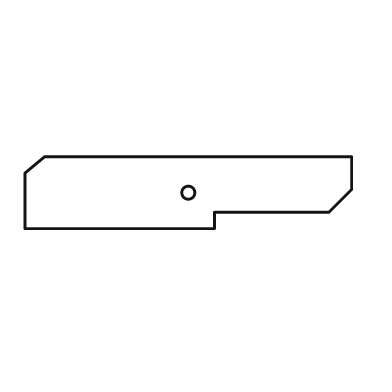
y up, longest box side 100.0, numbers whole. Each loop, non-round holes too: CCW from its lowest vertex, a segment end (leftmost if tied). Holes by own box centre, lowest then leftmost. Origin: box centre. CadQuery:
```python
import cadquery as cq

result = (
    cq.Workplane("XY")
    .moveTo(-50.0, -11.0)
    .lineTo(8.0, -11.0)
    .lineTo(8.0, -6.0)
    .lineTo(43.0, -6.0)
    .lineTo(50.0, 1.0)
    .lineTo(50.0, 11.0)
    .lineTo(-44.0, 11.0)
    .lineTo(-50.0, 6.0)
    .close()
    .moveTo(0.0, 0.0)
    .circle(2.0)
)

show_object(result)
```